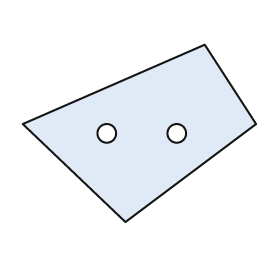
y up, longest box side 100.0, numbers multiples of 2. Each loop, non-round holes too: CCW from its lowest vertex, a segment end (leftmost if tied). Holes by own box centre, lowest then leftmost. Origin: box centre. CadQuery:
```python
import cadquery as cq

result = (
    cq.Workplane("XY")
    .moveTo(-6.0, -38.0)
    .lineTo(50.0, 4.0)
    .lineTo(28.0, 38.0)
    .lineTo(-50.0, 4.0)
    .close()
    .moveTo(-14.0, 0.0)
    .circle(4.0)
    .moveTo(16.0, 0.0)
    .circle(4.0)
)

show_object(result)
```